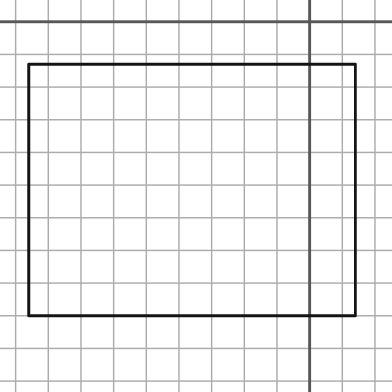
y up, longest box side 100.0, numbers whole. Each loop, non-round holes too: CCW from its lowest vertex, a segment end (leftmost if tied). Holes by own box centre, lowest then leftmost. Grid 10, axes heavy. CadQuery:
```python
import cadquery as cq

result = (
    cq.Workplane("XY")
    .moveTo(-86.0, -90.0)
    .lineTo(14.0, -90.0)
    .lineTo(14.0, -13.0)
    .lineTo(-86.0, -13.0)
    .close()
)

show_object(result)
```